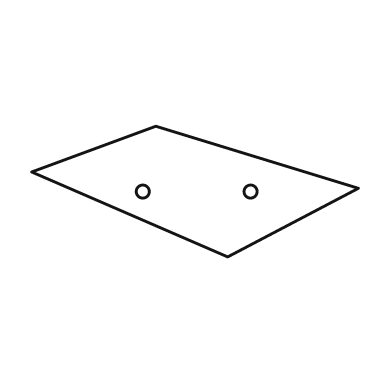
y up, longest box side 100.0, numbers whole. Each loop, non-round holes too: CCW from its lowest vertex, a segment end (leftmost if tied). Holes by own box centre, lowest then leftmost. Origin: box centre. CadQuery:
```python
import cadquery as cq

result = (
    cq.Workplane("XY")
    .moveTo(10.0, -20.0)
    .lineTo(50.0, 1.0)
    .lineTo(-12.0, 20.0)
    .lineTo(-50.0, 6.0)
    .close()
    .moveTo(-16.0, 0.0)
    .circle(2.0)
    .moveTo(17.0, 0.0)
    .circle(2.0)
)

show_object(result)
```